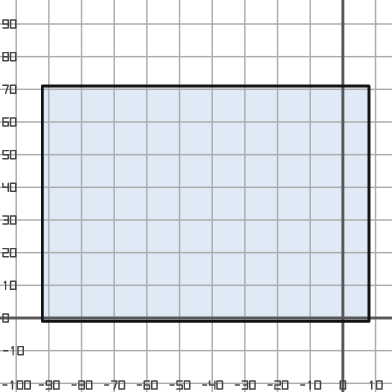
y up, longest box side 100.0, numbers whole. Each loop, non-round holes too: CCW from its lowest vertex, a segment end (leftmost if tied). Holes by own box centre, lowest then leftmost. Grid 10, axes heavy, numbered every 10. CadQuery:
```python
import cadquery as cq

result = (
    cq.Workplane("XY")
    .moveTo(-92.0, -1.0)
    .lineTo(8.0, -1.0)
    .lineTo(8.0, 71.0)
    .lineTo(-92.0, 71.0)
    .close()
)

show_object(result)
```